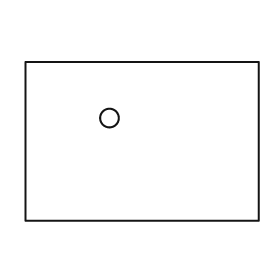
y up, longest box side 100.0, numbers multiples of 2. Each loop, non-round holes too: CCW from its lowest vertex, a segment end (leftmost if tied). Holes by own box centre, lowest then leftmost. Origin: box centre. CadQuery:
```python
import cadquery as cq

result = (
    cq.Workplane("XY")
    .moveTo(-50.0, -34.0)
    .lineTo(50.0, -34.0)
    .lineTo(50.0, 34.0)
    .lineTo(-50.0, 34.0)
    .close()
    .moveTo(-14.0, 10.0)
    .circle(4.0)
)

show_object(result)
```